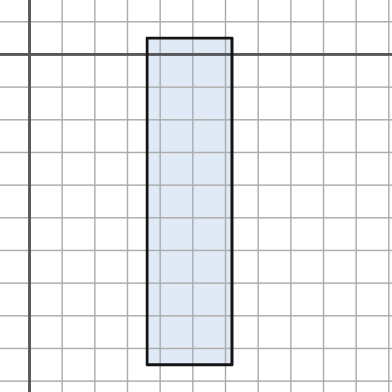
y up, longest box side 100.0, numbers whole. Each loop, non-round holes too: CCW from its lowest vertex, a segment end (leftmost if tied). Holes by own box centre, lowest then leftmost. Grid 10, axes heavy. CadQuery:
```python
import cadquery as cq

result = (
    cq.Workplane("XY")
    .moveTo(36.0, -95.0)
    .lineTo(62.0, -95.0)
    .lineTo(62.0, 5.0)
    .lineTo(36.0, 5.0)
    .close()
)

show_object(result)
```